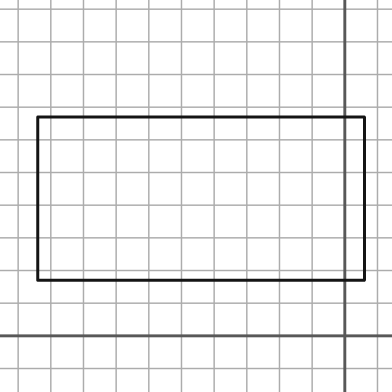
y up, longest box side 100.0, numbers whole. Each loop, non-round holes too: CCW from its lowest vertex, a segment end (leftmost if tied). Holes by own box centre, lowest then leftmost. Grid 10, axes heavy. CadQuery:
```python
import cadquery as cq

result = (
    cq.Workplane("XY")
    .moveTo(-94.0, 17.0)
    .lineTo(6.0, 17.0)
    .lineTo(6.0, 67.0)
    .lineTo(-94.0, 67.0)
    .close()
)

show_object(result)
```